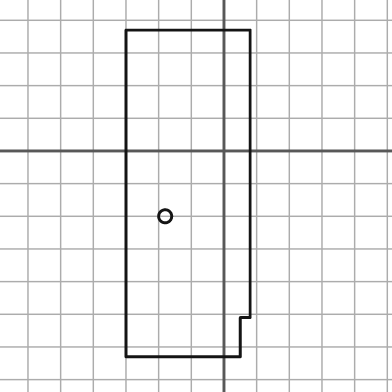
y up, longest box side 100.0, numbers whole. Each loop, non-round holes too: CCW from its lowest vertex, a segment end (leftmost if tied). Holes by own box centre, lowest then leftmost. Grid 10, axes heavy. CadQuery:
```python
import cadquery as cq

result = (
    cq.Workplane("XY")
    .moveTo(-30.0, -63.0)
    .lineTo(5.0, -63.0)
    .lineTo(5.0, -51.0)
    .lineTo(8.0, -51.0)
    .lineTo(8.0, 37.0)
    .lineTo(-30.0, 37.0)
    .close()
    .moveTo(-18.0, -20.0)
    .circle(2.0)
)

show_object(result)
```